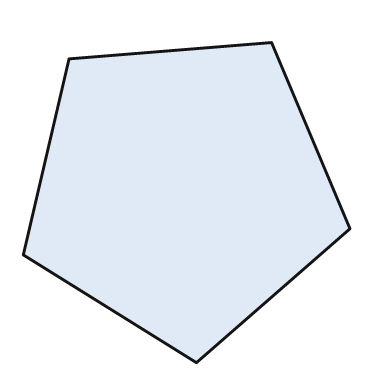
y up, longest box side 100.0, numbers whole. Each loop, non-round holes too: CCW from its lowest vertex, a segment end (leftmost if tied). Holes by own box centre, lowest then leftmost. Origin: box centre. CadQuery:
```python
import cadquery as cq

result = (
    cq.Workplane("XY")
    .moveTo(3.0, -49.0)
    .lineTo(50.0, -8.0)
    .lineTo(26.0, 49.0)
    .lineTo(-36.0, 44.0)
    .lineTo(-50.0, -16.0)
    .close()
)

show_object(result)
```